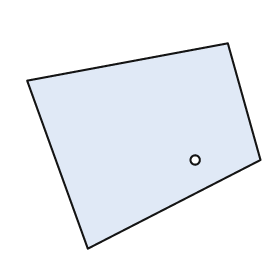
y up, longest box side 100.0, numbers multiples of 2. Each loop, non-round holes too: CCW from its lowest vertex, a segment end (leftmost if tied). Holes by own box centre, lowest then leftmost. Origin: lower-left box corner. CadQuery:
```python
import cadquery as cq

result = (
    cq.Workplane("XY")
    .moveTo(26.0, 0.0)
    .lineTo(100.0, 38.0)
    .lineTo(86.0, 88.0)
    .lineTo(0.0, 72.0)
    .close()
    .moveTo(72.0, 38.0)
    .circle(2.0)
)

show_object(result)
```